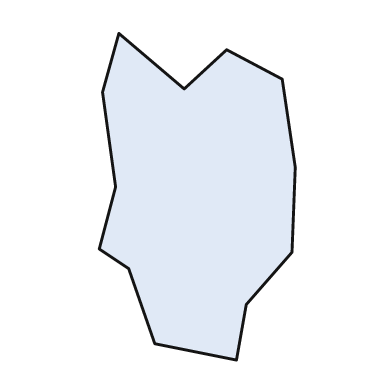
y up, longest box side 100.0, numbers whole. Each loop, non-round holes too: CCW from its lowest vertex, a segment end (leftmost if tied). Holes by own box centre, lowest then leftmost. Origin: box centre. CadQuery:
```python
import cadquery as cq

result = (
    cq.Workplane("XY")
    .moveTo(12.0, -50.0)
    .lineTo(15.0, -33.0)
    .lineTo(29.0, -17.0)
    .lineTo(30.0, 9.0)
    .lineTo(26.0, 36.0)
    .lineTo(9.0, 45.0)
    .lineTo(-4.0, 33.0)
    .lineTo(-24.0, 50.0)
    .lineTo(-29.0, 32.0)
    .lineTo(-25.0, 3.0)
    .lineTo(-30.0, -16.0)
    .lineTo(-21.0, -22.0)
    .lineTo(-13.0, -45.0)
    .close()
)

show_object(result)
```